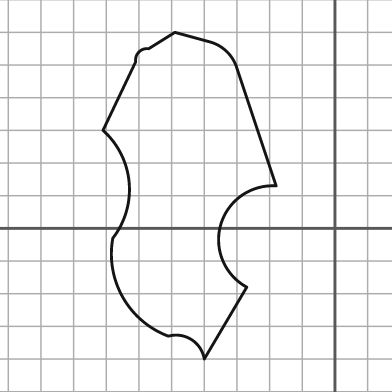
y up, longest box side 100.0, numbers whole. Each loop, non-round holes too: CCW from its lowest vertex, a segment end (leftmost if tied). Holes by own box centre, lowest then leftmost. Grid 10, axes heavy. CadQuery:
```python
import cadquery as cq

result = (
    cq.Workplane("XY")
    .moveTo(-40.0, -40.0)
    .lineTo(-27.0, -18.0)
    .threePointArc((-35.0, 1.0), (-18.0, 13.0))
    .lineTo(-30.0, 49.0)
    .threePointArc((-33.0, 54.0), (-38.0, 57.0))
    .lineTo(-49.0, 60.0)
    .lineTo(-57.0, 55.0)
    .threePointArc((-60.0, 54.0), (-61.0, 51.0))
    .lineTo(-71.0, 30.0)
    .threePointArc((-63.0, 14.0), (-68.0, -3.0))
    .threePointArc((-65.0, -21.0), (-51.0, -33.0))
    .threePointArc((-44.0, -34.0), (-40.0, -40.0))
    .close()
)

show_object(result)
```